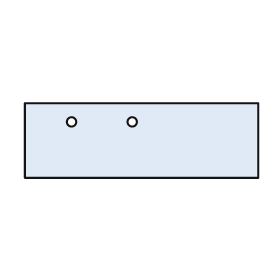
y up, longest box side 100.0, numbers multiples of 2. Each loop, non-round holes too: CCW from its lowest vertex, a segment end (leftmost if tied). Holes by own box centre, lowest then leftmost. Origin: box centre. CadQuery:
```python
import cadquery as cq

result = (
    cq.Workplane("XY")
    .moveTo(-50.0, -16.0)
    .lineTo(50.0, -16.0)
    .lineTo(50.0, 16.0)
    .lineTo(-50.0, 16.0)
    .close()
    .moveTo(-30.0, 8.0)
    .circle(2.0)
    .moveTo(-4.0, 8.0)
    .circle(2.0)
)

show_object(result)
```